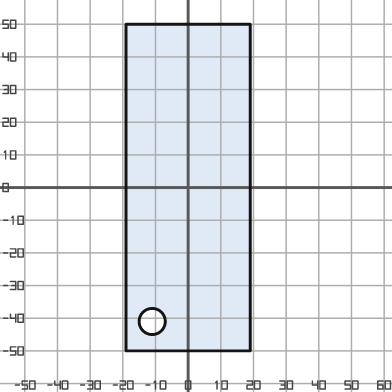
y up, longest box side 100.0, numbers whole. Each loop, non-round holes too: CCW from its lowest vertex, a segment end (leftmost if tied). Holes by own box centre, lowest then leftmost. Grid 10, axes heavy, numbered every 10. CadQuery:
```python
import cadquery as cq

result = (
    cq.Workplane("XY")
    .moveTo(-19.0, -50.0)
    .lineTo(19.0, -50.0)
    .lineTo(19.0, 50.0)
    .lineTo(-19.0, 50.0)
    .close()
    .moveTo(-11.0, -41.0)
    .circle(4.0)
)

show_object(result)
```